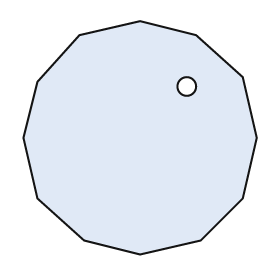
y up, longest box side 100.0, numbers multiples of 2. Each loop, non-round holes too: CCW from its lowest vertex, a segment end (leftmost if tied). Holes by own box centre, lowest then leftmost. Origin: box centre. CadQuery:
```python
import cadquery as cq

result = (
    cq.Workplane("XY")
    .moveTo(0.0, -50.0)
    .lineTo(26.0, -44.0)
    .lineTo(44.0, -26.0)
    .lineTo(50.0, 0.0)
    .lineTo(44.0, 26.0)
    .lineTo(24.0, 44.0)
    .lineTo(0.0, 50.0)
    .lineTo(-26.0, 44.0)
    .lineTo(-44.0, 24.0)
    .lineTo(-50.0, 0.0)
    .lineTo(-44.0, -26.0)
    .lineTo(-24.0, -44.0)
    .close()
    .moveTo(20.0, 22.0)
    .circle(4.0)
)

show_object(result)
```